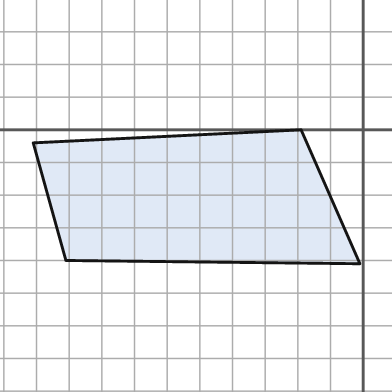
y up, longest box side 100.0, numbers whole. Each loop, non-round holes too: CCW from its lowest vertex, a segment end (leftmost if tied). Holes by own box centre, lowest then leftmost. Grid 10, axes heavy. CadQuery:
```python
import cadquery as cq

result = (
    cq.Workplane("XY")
    .moveTo(-1.0, -41.0)
    .lineTo(-19.0, 0.0)
    .lineTo(-101.0, -4.0)
    .lineTo(-91.0, -40.0)
    .close()
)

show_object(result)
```